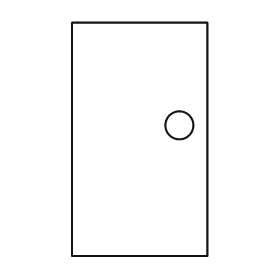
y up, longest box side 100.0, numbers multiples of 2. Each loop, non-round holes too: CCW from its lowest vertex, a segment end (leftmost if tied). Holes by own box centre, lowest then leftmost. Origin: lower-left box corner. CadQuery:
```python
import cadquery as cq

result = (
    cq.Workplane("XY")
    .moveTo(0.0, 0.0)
    .lineTo(58.0, 0.0)
    .lineTo(58.0, 100.0)
    .lineTo(0.0, 100.0)
    .close()
    .moveTo(46.0, 56.0)
    .circle(6.0)
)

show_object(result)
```